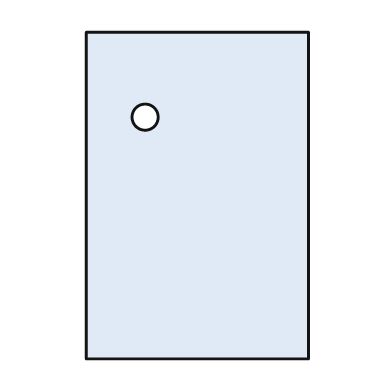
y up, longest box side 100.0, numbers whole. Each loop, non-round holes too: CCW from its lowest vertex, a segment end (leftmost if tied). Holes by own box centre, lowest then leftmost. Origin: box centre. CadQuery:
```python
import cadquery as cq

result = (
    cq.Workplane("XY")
    .moveTo(-34.0, -50.0)
    .lineTo(34.0, -50.0)
    .lineTo(34.0, 50.0)
    .lineTo(-34.0, 50.0)
    .close()
    .moveTo(-16.0, 24.0)
    .circle(4.0)
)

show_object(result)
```